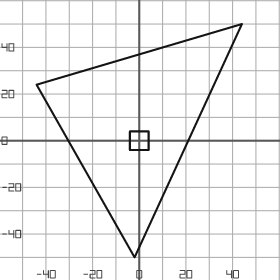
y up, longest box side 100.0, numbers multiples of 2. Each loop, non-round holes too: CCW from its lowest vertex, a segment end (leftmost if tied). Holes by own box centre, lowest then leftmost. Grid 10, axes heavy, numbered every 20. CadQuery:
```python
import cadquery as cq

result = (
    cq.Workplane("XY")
    .moveTo(-2.0, -50.0)
    .lineTo(44.0, 50.0)
    .lineTo(-44.0, 24.0)
    .close()
    .moveTo(-4.0, -4.0)
    .lineTo(4.0, -4.0)
    .lineTo(4.0, 4.0)
    .lineTo(-4.0, 4.0)
    .close()
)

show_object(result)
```